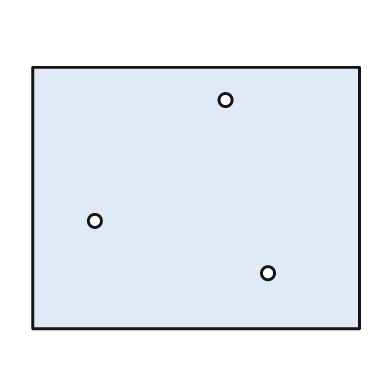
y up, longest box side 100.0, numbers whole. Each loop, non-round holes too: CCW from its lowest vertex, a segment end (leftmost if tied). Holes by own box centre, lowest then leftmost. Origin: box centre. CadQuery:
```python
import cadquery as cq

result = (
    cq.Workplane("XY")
    .moveTo(-50.0, -40.0)
    .lineTo(50.0, -40.0)
    .lineTo(50.0, 40.0)
    .lineTo(-50.0, 40.0)
    .close()
    .moveTo(22.0, -23.0)
    .circle(2.0)
    .moveTo(-31.0, -7.0)
    .circle(2.0)
    .moveTo(9.0, 30.0)
    .circle(2.0)
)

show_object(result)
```